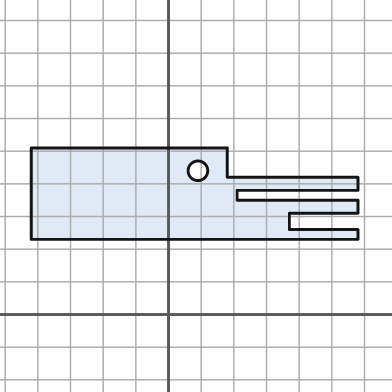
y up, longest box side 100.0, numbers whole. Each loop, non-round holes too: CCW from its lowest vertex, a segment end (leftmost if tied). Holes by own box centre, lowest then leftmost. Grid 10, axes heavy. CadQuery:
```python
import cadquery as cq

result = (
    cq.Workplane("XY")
    .moveTo(-42.0, 23.0)
    .lineTo(58.0, 23.0)
    .lineTo(58.0, 26.0)
    .lineTo(37.0, 26.0)
    .lineTo(37.0, 31.0)
    .lineTo(58.0, 31.0)
    .lineTo(58.0, 35.0)
    .lineTo(21.0, 35.0)
    .lineTo(21.0, 38.0)
    .lineTo(58.0, 38.0)
    .lineTo(58.0, 42.0)
    .lineTo(18.0, 42.0)
    .lineTo(18.0, 51.0)
    .lineTo(-42.0, 51.0)
    .close()
    .moveTo(9.0, 44.0)
    .circle(3.0)
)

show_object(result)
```